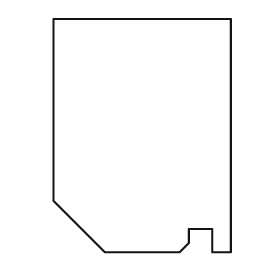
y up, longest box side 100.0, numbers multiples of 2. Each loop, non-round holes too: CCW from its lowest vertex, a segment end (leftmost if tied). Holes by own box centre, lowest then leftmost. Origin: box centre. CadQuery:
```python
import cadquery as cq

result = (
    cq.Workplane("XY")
    .moveTo(-16.0, -50.0)
    .lineTo(16.0, -50.0)
    .lineTo(20.0, -46.0)
    .lineTo(20.0, -40.0)
    .lineTo(30.0, -40.0)
    .lineTo(30.0, -50.0)
    .lineTo(38.0, -50.0)
    .lineTo(38.0, 50.0)
    .lineTo(-38.0, 50.0)
    .lineTo(-38.0, -28.0)
    .close()
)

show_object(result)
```